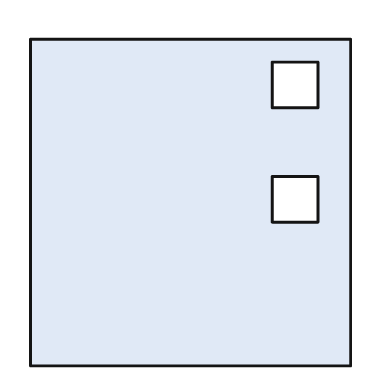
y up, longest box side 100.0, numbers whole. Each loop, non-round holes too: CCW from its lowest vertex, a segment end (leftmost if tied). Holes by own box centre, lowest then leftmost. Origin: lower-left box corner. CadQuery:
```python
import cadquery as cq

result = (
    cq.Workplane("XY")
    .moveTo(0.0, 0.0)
    .lineTo(98.0, 0.0)
    .lineTo(98.0, 100.0)
    .lineTo(0.0, 100.0)
    .close()
    .moveTo(74.0, 44.0)
    .lineTo(88.0, 44.0)
    .lineTo(88.0, 58.0)
    .lineTo(74.0, 58.0)
    .close()
    .moveTo(74.0, 79.0)
    .lineTo(88.0, 79.0)
    .lineTo(88.0, 93.0)
    .lineTo(74.0, 93.0)
    .close()
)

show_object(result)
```